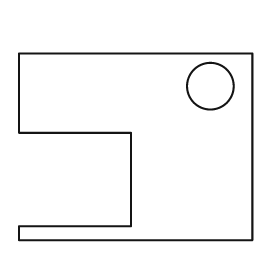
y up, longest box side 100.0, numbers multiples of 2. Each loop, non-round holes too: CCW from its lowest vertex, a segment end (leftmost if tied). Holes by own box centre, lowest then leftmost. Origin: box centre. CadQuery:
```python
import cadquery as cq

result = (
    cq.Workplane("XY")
    .moveTo(-50.0, -40.0)
    .lineTo(50.0, -40.0)
    .lineTo(50.0, 40.0)
    .lineTo(-50.0, 40.0)
    .lineTo(-50.0, 6.0)
    .lineTo(-2.0, 6.0)
    .lineTo(-2.0, -34.0)
    .lineTo(-50.0, -34.0)
    .close()
    .moveTo(32.0, 26.0)
    .circle(10.0)
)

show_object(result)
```